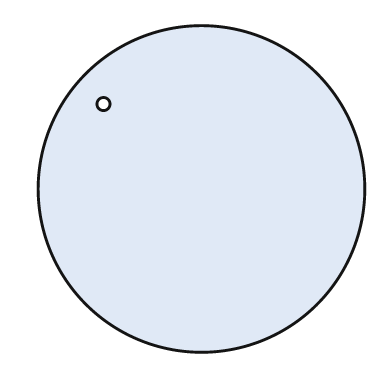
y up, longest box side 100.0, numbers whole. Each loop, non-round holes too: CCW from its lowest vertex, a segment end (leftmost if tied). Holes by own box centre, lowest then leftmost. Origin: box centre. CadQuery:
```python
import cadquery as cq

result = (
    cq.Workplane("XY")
    .moveTo(0.0, 0.0)
    .circle(50.0)
    .moveTo(-30.0, 26.0)
    .circle(2.0)
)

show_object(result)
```